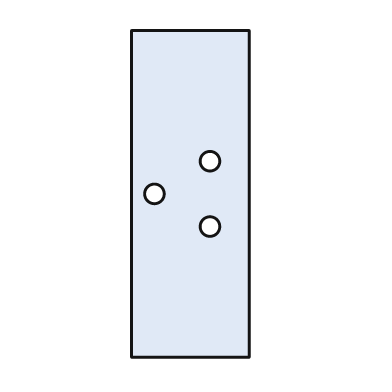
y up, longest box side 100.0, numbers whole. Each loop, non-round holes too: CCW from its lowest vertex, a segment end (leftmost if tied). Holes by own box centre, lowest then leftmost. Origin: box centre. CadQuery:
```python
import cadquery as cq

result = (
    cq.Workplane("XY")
    .moveTo(-18.0, -50.0)
    .lineTo(18.0, -50.0)
    .lineTo(18.0, 50.0)
    .lineTo(-18.0, 50.0)
    .close()
    .moveTo(6.0, -10.0)
    .circle(3.0)
    .moveTo(-11.0, 0.0)
    .circle(3.0)
    .moveTo(6.0, 10.0)
    .circle(3.0)
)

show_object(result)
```